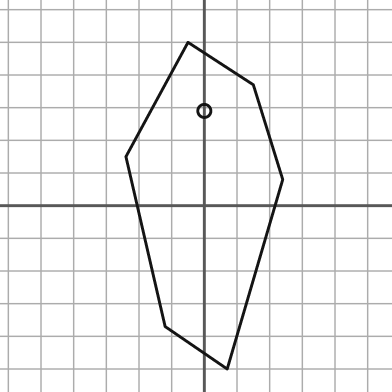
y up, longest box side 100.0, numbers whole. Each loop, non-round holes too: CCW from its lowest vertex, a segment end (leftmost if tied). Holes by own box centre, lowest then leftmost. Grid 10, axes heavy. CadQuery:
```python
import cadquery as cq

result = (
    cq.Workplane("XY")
    .moveTo(7.0, -50.0)
    .lineTo(24.0, 8.0)
    .lineTo(15.0, 37.0)
    .lineTo(-5.0, 50.0)
    .lineTo(-24.0, 15.0)
    .lineTo(-12.0, -37.0)
    .close()
    .moveTo(0.0, 29.0)
    .circle(2.0)
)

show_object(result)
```